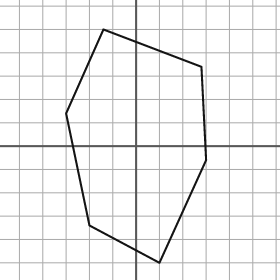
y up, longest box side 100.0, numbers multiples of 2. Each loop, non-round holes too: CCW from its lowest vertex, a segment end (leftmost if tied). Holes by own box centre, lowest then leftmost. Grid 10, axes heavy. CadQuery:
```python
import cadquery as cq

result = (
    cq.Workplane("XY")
    .moveTo(10.0, -50.0)
    .lineTo(30.0, -6.0)
    .lineTo(28.0, 34.0)
    .lineTo(-14.0, 50.0)
    .lineTo(-30.0, 14.0)
    .lineTo(-20.0, -34.0)
    .close()
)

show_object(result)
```